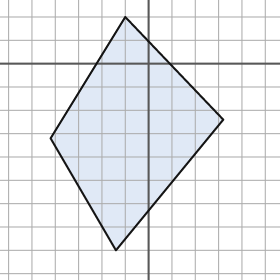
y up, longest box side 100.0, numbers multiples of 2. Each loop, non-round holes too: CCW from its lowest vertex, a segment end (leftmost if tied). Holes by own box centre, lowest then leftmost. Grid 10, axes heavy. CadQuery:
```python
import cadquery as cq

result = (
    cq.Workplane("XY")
    .moveTo(-14.0, -80.0)
    .lineTo(32.0, -24.0)
    .lineTo(-10.0, 20.0)
    .lineTo(-42.0, -32.0)
    .close()
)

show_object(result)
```